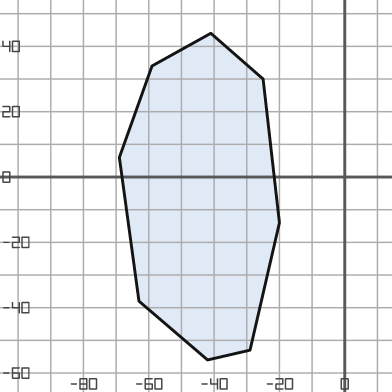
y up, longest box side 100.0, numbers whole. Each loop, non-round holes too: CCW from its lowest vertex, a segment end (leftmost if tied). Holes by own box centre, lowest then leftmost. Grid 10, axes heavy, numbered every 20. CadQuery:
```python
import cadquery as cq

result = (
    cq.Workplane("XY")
    .moveTo(-42.0, -56.0)
    .lineTo(-29.0, -53.0)
    .lineTo(-20.0, -14.0)
    .lineTo(-25.0, 30.0)
    .lineTo(-41.0, 44.0)
    .lineTo(-59.0, 34.0)
    .lineTo(-69.0, 6.0)
    .lineTo(-63.0, -38.0)
    .close()
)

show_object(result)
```